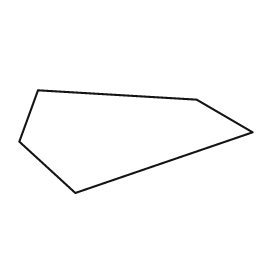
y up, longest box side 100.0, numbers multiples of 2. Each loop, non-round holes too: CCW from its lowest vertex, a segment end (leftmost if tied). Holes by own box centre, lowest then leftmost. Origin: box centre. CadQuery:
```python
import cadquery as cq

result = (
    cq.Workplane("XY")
    .moveTo(-26.0, -22.0)
    .lineTo(50.0, 4.0)
    .lineTo(26.0, 18.0)
    .lineTo(-42.0, 22.0)
    .lineTo(-50.0, 0.0)
    .close()
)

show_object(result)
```